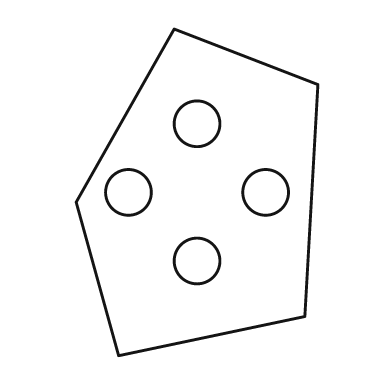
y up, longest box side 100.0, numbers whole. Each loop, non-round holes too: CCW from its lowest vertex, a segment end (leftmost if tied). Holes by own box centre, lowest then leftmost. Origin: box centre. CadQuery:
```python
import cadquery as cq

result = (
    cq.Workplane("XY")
    .moveTo(-24.0, -50.0)
    .lineTo(33.0, -38.0)
    .lineTo(37.0, 33.0)
    .lineTo(-7.0, 50.0)
    .lineTo(-37.0, -3.0)
    .close()
    .moveTo(0.0, -21.0)
    .circle(7.0)
    .moveTo(-21.0, 0.0)
    .circle(7.0)
    .moveTo(21.0, 0.0)
    .circle(7.0)
    .moveTo(0.0, 21.0)
    .circle(7.0)
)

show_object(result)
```